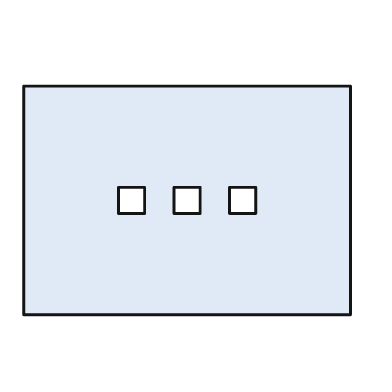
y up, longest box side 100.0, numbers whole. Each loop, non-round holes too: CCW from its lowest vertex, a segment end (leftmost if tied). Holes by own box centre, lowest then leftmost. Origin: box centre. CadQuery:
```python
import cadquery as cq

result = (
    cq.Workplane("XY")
    .moveTo(-50.0, -35.0)
    .lineTo(50.0, -35.0)
    .lineTo(50.0, 35.0)
    .lineTo(-50.0, 35.0)
    .close()
    .moveTo(-21.0, -4.0)
    .lineTo(-13.0, -4.0)
    .lineTo(-13.0, 4.0)
    .lineTo(-21.0, 4.0)
    .close()
    .moveTo(-4.0, -4.0)
    .lineTo(4.0, -4.0)
    .lineTo(4.0, 4.0)
    .lineTo(-4.0, 4.0)
    .close()
    .moveTo(13.0, -4.0)
    .lineTo(21.0, -4.0)
    .lineTo(21.0, 4.0)
    .lineTo(13.0, 4.0)
    .close()
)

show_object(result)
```